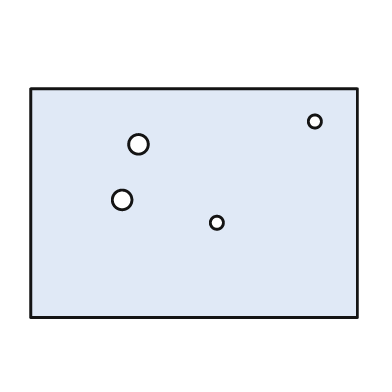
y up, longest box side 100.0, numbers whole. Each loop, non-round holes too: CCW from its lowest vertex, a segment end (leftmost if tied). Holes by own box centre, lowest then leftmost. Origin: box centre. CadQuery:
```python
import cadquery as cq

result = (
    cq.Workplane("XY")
    .moveTo(-50.0, -35.0)
    .lineTo(50.0, -35.0)
    .lineTo(50.0, 35.0)
    .lineTo(-50.0, 35.0)
    .close()
    .moveTo(7.0, -6.0)
    .circle(2.0)
    .moveTo(-22.0, 1.0)
    .circle(3.0)
    .moveTo(-17.0, 18.0)
    .circle(3.0)
    .moveTo(37.0, 25.0)
    .circle(2.0)
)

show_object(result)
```